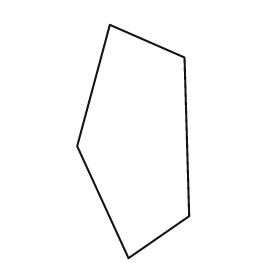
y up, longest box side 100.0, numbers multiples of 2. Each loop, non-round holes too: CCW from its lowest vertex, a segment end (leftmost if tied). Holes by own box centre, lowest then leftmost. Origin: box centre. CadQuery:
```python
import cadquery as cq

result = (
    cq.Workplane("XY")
    .moveTo(-2.0, -50.0)
    .lineTo(24.0, -32.0)
    .lineTo(22.0, 36.0)
    .lineTo(-10.0, 50.0)
    .lineTo(-24.0, -2.0)
    .close()
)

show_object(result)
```